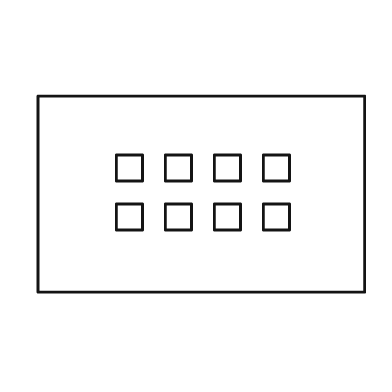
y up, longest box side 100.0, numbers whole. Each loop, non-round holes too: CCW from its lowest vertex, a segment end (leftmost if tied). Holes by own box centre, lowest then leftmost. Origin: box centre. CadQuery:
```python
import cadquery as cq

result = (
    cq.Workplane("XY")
    .moveTo(-50.0, -30.0)
    .lineTo(50.0, -30.0)
    .lineTo(50.0, 30.0)
    .lineTo(-50.0, 30.0)
    .close()
    .moveTo(-26.0, -11.0)
    .lineTo(-18.0, -11.0)
    .lineTo(-18.0, -3.0)
    .lineTo(-26.0, -3.0)
    .close()
    .moveTo(-11.0, -11.0)
    .lineTo(-3.0, -11.0)
    .lineTo(-3.0, -3.0)
    .lineTo(-11.0, -3.0)
    .close()
    .moveTo(4.0, -11.0)
    .lineTo(12.0, -11.0)
    .lineTo(12.0, -3.0)
    .lineTo(4.0, -3.0)
    .close()
    .moveTo(19.0, -11.0)
    .lineTo(27.0, -11.0)
    .lineTo(27.0, -3.0)
    .lineTo(19.0, -3.0)
    .close()
    .moveTo(-26.0, 4.0)
    .lineTo(-18.0, 4.0)
    .lineTo(-18.0, 12.0)
    .lineTo(-26.0, 12.0)
    .close()
    .moveTo(-11.0, 4.0)
    .lineTo(-3.0, 4.0)
    .lineTo(-3.0, 12.0)
    .lineTo(-11.0, 12.0)
    .close()
    .moveTo(4.0, 4.0)
    .lineTo(12.0, 4.0)
    .lineTo(12.0, 12.0)
    .lineTo(4.0, 12.0)
    .close()
    .moveTo(19.0, 4.0)
    .lineTo(27.0, 4.0)
    .lineTo(27.0, 12.0)
    .lineTo(19.0, 12.0)
    .close()
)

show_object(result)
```